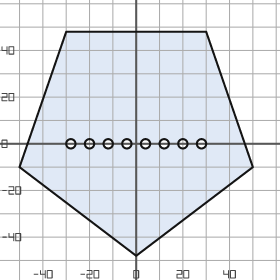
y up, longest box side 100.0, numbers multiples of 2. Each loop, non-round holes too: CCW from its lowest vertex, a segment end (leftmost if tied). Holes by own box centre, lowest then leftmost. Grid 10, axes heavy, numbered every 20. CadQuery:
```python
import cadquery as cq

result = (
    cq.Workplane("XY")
    .moveTo(0.0, -48.0)
    .lineTo(50.0, -10.0)
    .lineTo(30.0, 48.0)
    .lineTo(-30.0, 48.0)
    .lineTo(-50.0, -10.0)
    .close()
    .moveTo(-28.0, 0.0)
    .circle(2.0)
    .moveTo(-20.0, 0.0)
    .circle(2.0)
    .moveTo(-12.0, 0.0)
    .circle(2.0)
    .moveTo(-4.0, 0.0)
    .circle(2.0)
    .moveTo(4.0, 0.0)
    .circle(2.0)
    .moveTo(12.0, 0.0)
    .circle(2.0)
    .moveTo(20.0, 0.0)
    .circle(2.0)
    .moveTo(28.0, 0.0)
    .circle(2.0)
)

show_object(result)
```